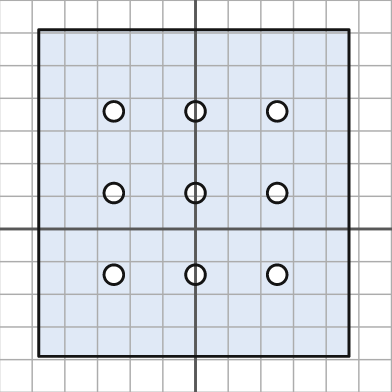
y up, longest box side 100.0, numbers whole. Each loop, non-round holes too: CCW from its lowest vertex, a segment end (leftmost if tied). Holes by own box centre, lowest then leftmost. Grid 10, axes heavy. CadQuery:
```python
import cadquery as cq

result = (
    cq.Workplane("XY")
    .moveTo(-48.0, -39.0)
    .lineTo(47.0, -39.0)
    .lineTo(47.0, 61.0)
    .lineTo(-48.0, 61.0)
    .close()
    .moveTo(-25.0, -14.0)
    .circle(3.0)
    .moveTo(0.0, -14.0)
    .circle(3.0)
    .moveTo(25.0, -14.0)
    .circle(3.0)
    .moveTo(-25.0, 11.0)
    .circle(3.0)
    .moveTo(0.0, 11.0)
    .circle(3.0)
    .moveTo(25.0, 11.0)
    .circle(3.0)
    .moveTo(-25.0, 36.0)
    .circle(3.0)
    .moveTo(0.0, 36.0)
    .circle(3.0)
    .moveTo(25.0, 36.0)
    .circle(3.0)
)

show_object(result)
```